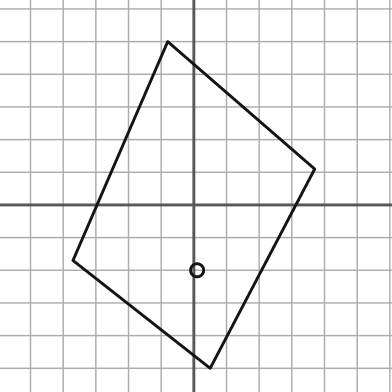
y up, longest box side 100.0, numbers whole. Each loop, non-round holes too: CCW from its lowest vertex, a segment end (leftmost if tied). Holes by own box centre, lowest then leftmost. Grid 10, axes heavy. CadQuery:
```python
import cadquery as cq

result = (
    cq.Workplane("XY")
    .moveTo(5.0, -50.0)
    .lineTo(37.0, 11.0)
    .lineTo(-8.0, 50.0)
    .lineTo(-37.0, -17.0)
    .close()
    .moveTo(1.0, -20.0)
    .circle(2.0)
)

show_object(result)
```